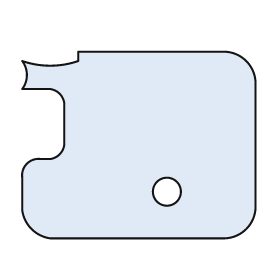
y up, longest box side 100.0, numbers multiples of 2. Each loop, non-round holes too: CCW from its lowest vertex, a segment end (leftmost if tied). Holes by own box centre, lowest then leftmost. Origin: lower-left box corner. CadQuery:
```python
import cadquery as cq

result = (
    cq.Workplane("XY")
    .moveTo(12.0, 0.0)
    .lineTo(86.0, 0.0)
    .threePointArc((96.0, 4.0), (100.0, 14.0))
    .lineTo(100.0, 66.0)
    .threePointArc((96.0, 76.0), (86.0, 80.0))
    .lineTo(24.0, 80.0)
    .lineTo(24.0, 76.0)
    .threePointArc((12.0, 74.0), (0.0, 76.0))
    .threePointArc((2.0, 70.0), (0.0, 64.0))
    .lineTo(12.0, 64.0)
    .threePointArc((16.0, 62.0), (18.0, 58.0))
    .lineTo(18.0, 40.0)
    .threePointArc((16.0, 36.0), (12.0, 34.0))
    .lineTo(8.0, 34.0)
    .threePointArc((2.0, 32.0), (0.0, 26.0))
    .lineTo(0.0, 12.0)
    .threePointArc((4.0, 4.0), (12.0, 0.0))
    .close()
    .moveTo(62.0, 20.0)
    .circle(6.0)
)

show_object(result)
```